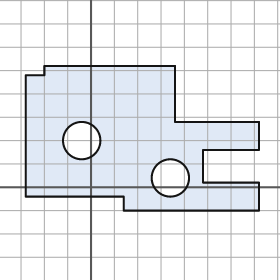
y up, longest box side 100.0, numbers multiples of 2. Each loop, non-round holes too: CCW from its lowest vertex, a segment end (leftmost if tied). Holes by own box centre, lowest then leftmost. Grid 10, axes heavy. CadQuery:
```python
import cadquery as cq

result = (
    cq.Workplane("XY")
    .moveTo(14.0, -10.0)
    .lineTo(72.0, -10.0)
    .lineTo(72.0, 2.0)
    .lineTo(48.0, 2.0)
    .lineTo(48.0, 16.0)
    .lineTo(72.0, 16.0)
    .lineTo(72.0, 28.0)
    .lineTo(36.0, 28.0)
    .lineTo(36.0, 52.0)
    .lineTo(-20.0, 52.0)
    .lineTo(-20.0, 48.0)
    .lineTo(-28.0, 48.0)
    .lineTo(-28.0, -4.0)
    .lineTo(14.0, -4.0)
    .close()
    .moveTo(34.0, 4.0)
    .circle(8.0)
    .moveTo(-4.0, 20.0)
    .circle(8.0)
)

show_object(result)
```